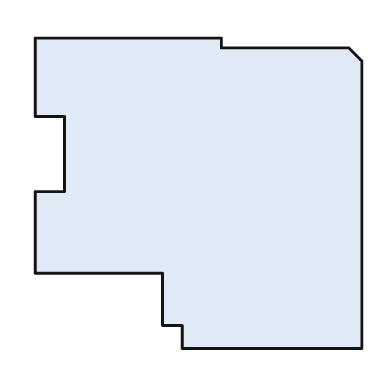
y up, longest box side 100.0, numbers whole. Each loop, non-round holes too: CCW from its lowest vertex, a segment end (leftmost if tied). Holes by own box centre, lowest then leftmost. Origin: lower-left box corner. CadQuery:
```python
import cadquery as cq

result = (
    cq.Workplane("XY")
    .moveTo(45.0, 0.0)
    .lineTo(100.0, 0.0)
    .lineTo(100.0, 88.0)
    .lineTo(96.0, 92.0)
    .lineTo(57.0, 92.0)
    .lineTo(57.0, 95.0)
    .lineTo(0.0, 95.0)
    .lineTo(0.0, 71.0)
    .lineTo(9.0, 71.0)
    .lineTo(9.0, 48.0)
    .lineTo(0.0, 48.0)
    .lineTo(0.0, 23.0)
    .lineTo(39.0, 23.0)
    .lineTo(39.0, 7.0)
    .lineTo(45.0, 7.0)
    .close()
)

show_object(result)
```